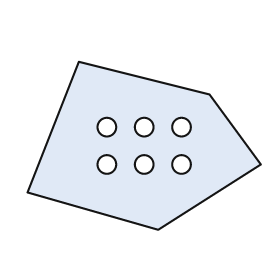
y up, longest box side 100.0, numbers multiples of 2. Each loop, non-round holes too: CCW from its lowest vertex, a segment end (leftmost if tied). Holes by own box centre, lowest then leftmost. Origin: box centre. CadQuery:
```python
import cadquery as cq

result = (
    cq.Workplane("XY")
    .moveTo(6.0, -36.0)
    .lineTo(50.0, -8.0)
    .lineTo(28.0, 22.0)
    .lineTo(-28.0, 36.0)
    .lineTo(-50.0, -20.0)
    .close()
    .moveTo(-16.0, -8.0)
    .circle(4.0)
    .moveTo(0.0, -8.0)
    .circle(4.0)
    .moveTo(16.0, -8.0)
    .circle(4.0)
    .moveTo(-16.0, 8.0)
    .circle(4.0)
    .moveTo(0.0, 8.0)
    .circle(4.0)
    .moveTo(16.0, 8.0)
    .circle(4.0)
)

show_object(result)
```